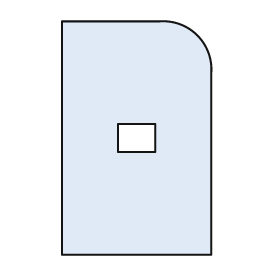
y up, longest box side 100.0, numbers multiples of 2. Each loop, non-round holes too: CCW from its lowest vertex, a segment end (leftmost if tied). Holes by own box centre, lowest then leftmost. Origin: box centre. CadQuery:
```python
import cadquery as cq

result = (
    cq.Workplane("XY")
    .moveTo(-32.0, -50.0)
    .lineTo(32.0, -50.0)
    .lineTo(32.0, 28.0)
    .threePointArc((26.0, 44.0), (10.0, 50.0))
    .lineTo(-32.0, 50.0)
    .close()
    .moveTo(-8.0, -6.0)
    .lineTo(8.0, -6.0)
    .lineTo(8.0, 6.0)
    .lineTo(-8.0, 6.0)
    .close()
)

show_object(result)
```